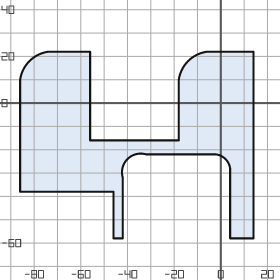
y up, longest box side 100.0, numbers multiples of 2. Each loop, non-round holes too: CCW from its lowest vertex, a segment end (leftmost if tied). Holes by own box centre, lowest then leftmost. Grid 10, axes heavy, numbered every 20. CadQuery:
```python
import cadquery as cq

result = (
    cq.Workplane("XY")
    .moveTo(-46.0, -58.0)
    .lineTo(-42.0, -58.0)
    .lineTo(-42.0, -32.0)
    .threePointArc((-40.0, -24.0), (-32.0, -22.0))
    .lineTo(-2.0, -22.0)
    .threePointArc((2.0, -24.0), (4.0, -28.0))
    .lineTo(4.0, -58.0)
    .lineTo(14.0, -58.0)
    .lineTo(14.0, 22.0)
    .lineTo(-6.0, 22.0)
    .threePointArc((-14.0, 18.0), (-18.0, 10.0))
    .lineTo(-18.0, -16.0)
    .lineTo(-56.0, -16.0)
    .lineTo(-56.0, 22.0)
    .lineTo(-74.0, 22.0)
    .threePointArc((-82.0, 18.0), (-86.0, 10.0))
    .lineTo(-86.0, -38.0)
    .lineTo(-46.0, -38.0)
    .close()
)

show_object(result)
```